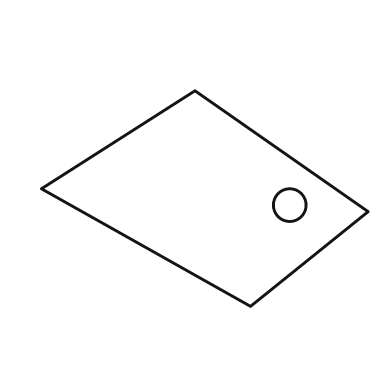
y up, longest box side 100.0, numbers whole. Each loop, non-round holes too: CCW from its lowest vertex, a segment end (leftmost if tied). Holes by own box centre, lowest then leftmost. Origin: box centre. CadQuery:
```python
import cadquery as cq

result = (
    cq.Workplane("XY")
    .moveTo(14.0, -33.0)
    .lineTo(50.0, -4.0)
    .lineTo(-3.0, 33.0)
    .lineTo(-50.0, 3.0)
    .close()
    .moveTo(26.0, -2.0)
    .circle(5.0)
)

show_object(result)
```